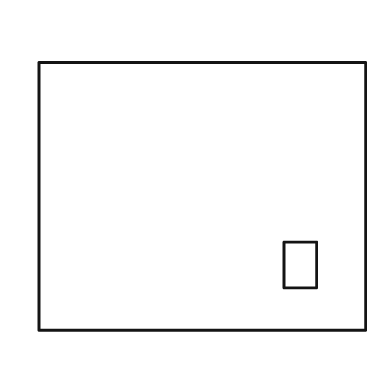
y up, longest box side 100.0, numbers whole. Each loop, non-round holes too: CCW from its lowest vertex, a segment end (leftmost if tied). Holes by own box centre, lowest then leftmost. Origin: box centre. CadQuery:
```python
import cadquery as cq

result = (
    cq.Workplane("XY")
    .moveTo(-50.0, -41.0)
    .lineTo(50.0, -41.0)
    .lineTo(50.0, 41.0)
    .lineTo(-50.0, 41.0)
    .close()
    .moveTo(25.0, -28.0)
    .lineTo(35.0, -28.0)
    .lineTo(35.0, -14.0)
    .lineTo(25.0, -14.0)
    .close()
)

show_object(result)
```